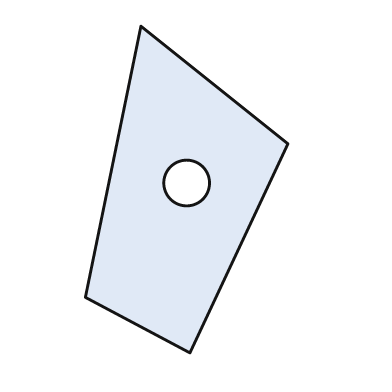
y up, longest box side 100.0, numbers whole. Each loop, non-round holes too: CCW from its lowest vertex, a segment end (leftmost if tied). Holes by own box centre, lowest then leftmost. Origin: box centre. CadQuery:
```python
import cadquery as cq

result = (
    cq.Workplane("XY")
    .moveTo(1.0, -50.0)
    .lineTo(31.0, 14.0)
    .lineTo(-14.0, 50.0)
    .lineTo(-31.0, -33.0)
    .close()
    .moveTo(0.0, 2.0)
    .circle(7.0)
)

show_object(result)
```